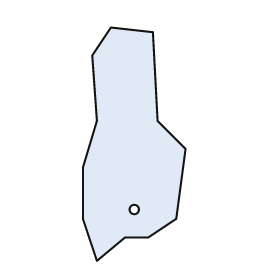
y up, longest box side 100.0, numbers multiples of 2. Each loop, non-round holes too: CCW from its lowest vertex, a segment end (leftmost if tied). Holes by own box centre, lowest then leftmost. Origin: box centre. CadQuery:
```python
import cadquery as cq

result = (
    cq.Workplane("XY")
    .moveTo(-16.0, -50.0)
    .lineTo(-4.0, -40.0)
    .lineTo(6.0, -40.0)
    .lineTo(18.0, -32.0)
    .lineTo(22.0, -2.0)
    .lineTo(10.0, 10.0)
    .lineTo(8.0, 48.0)
    .lineTo(-10.0, 50.0)
    .lineTo(-18.0, 38.0)
    .lineTo(-16.0, 10.0)
    .lineTo(-22.0, -10.0)
    .lineTo(-22.0, -32.0)
    .close()
    .moveTo(0.0, -28.0)
    .circle(2.0)
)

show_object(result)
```